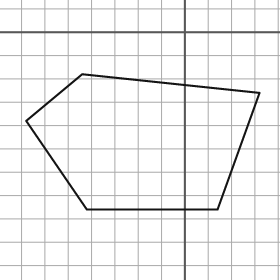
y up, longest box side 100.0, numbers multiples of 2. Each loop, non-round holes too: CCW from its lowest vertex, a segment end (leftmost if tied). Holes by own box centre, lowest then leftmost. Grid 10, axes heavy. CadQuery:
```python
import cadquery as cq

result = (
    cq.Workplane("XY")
    .moveTo(-42.0, -76.0)
    .lineTo(14.0, -76.0)
    .lineTo(32.0, -26.0)
    .lineTo(-44.0, -18.0)
    .lineTo(-68.0, -38.0)
    .close()
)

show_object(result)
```